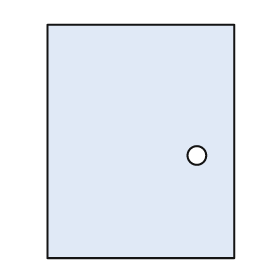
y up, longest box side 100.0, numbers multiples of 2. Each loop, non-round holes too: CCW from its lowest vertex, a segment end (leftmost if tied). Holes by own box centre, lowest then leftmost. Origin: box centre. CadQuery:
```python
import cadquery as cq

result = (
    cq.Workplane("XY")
    .moveTo(-40.0, -50.0)
    .lineTo(40.0, -50.0)
    .lineTo(40.0, 50.0)
    .lineTo(-40.0, 50.0)
    .close()
    .moveTo(24.0, -6.0)
    .circle(4.0)
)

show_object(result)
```